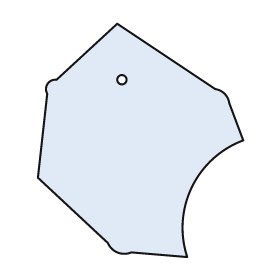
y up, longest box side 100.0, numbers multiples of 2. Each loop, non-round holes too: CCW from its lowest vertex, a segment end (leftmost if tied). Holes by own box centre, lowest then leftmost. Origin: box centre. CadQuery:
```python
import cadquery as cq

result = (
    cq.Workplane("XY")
    .moveTo(20.0, -50.0)
    .threePointArc((22.0, -20.0), (44.0, 0.0))
    .lineTo(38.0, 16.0)
    .threePointArc((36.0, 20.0), (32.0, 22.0))
    .lineTo(-10.0, 50.0)
    .lineTo(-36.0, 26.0)
    .threePointArc((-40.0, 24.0), (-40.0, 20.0))
    .lineTo(-44.0, -16.0)
    .lineTo(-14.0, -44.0)
    .threePointArc((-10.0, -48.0), (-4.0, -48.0))
    .close()
    .moveTo(-8.0, 26.0)
    .circle(2.0)
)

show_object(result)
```